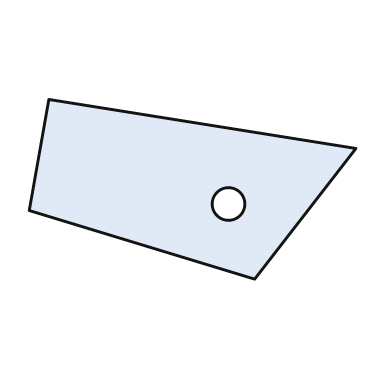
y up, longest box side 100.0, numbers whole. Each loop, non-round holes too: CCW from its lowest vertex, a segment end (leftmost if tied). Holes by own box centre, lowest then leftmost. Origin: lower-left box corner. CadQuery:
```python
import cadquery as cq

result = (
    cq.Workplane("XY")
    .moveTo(69.0, 0.0)
    .lineTo(100.0, 40.0)
    .lineTo(6.0, 55.0)
    .lineTo(0.0, 21.0)
    .close()
    .moveTo(61.0, 23.0)
    .circle(5.0)
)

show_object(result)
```